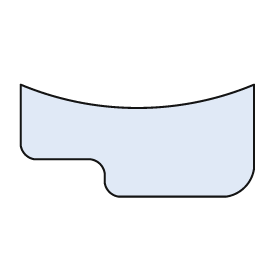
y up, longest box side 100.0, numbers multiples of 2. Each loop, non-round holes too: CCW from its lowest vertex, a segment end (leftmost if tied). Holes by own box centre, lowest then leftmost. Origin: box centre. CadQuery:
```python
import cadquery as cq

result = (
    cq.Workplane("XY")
    .moveTo(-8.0, -24.0)
    .lineTo(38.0, -24.0)
    .threePointArc((46.0, -20.0), (50.0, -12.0))
    .lineTo(50.0, 24.0)
    .threePointArc((0.0, 14.0), (-50.0, 24.0))
    .lineTo(-50.0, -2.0)
    .threePointArc((-48.0, -6.0), (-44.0, -8.0))
    .lineTo(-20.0, -8.0)
    .threePointArc((-16.0, -10.0), (-14.0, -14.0))
    .lineTo(-14.0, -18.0)
    .threePointArc((-12.0, -22.0), (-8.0, -24.0))
    .close()
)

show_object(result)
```